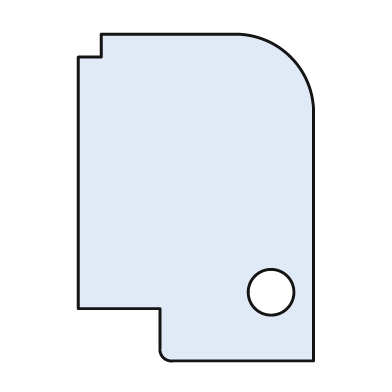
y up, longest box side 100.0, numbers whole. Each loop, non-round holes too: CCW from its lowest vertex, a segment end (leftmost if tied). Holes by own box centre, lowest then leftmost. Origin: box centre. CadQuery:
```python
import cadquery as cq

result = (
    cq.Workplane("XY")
    .moveTo(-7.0, -50.0)
    .lineTo(36.0, -50.0)
    .lineTo(36.0, 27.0)
    .threePointArc((29.0, 43.0), (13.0, 50.0))
    .lineTo(-29.0, 50.0)
    .lineTo(-29.0, 43.0)
    .lineTo(-36.0, 43.0)
    .lineTo(-36.0, -34.0)
    .lineTo(-11.0, -34.0)
    .lineTo(-11.0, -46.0)
    .threePointArc((-10.0, -49.0), (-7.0, -50.0))
    .close()
    .moveTo(23.0, -29.0)
    .circle(7.0)
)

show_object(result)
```